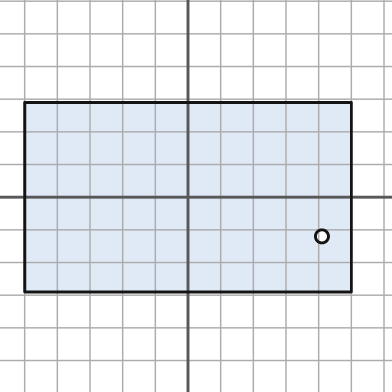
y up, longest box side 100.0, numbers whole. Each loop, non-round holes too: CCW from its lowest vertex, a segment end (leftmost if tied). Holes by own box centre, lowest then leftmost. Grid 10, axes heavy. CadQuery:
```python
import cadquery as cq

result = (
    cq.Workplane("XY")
    .moveTo(-50.0, -29.0)
    .lineTo(50.0, -29.0)
    .lineTo(50.0, 29.0)
    .lineTo(-50.0, 29.0)
    .close()
    .moveTo(41.0, -12.0)
    .circle(2.0)
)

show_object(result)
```